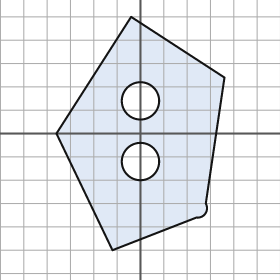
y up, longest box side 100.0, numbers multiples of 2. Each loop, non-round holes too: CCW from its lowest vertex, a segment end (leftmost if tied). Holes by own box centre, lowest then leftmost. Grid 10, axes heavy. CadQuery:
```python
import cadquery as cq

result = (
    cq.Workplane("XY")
    .moveTo(-12.0, -50.0)
    .lineTo(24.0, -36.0)
    .threePointArc((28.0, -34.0), (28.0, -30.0))
    .lineTo(36.0, 24.0)
    .lineTo(-4.0, 50.0)
    .lineTo(-36.0, 0.0)
    .close()
    .moveTo(0.0, -12.0)
    .circle(8.0)
    .moveTo(0.0, 14.0)
    .circle(8.0)
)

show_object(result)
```